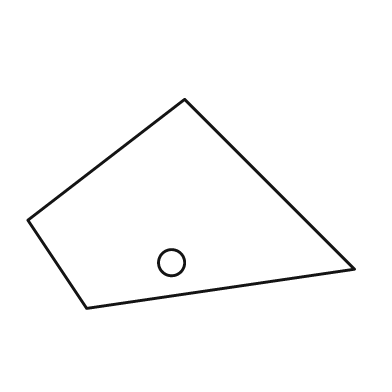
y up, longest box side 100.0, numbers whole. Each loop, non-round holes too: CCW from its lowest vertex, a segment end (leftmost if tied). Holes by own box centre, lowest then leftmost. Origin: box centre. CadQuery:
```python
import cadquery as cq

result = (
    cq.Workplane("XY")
    .moveTo(-32.0, -32.0)
    .lineTo(50.0, -20.0)
    .lineTo(-2.0, 32.0)
    .lineTo(-50.0, -5.0)
    .close()
    .moveTo(-6.0, -18.0)
    .circle(4.0)
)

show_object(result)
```